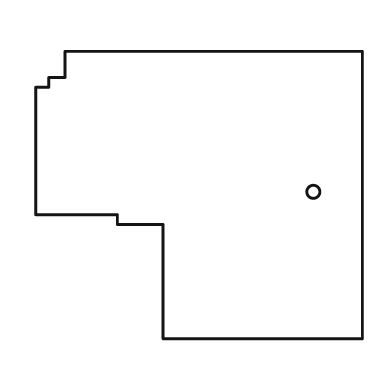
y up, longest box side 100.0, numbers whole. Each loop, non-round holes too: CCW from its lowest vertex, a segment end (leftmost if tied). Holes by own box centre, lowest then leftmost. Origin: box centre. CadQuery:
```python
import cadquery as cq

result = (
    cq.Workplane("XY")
    .moveTo(-11.0, -44.0)
    .lineTo(50.0, -44.0)
    .lineTo(50.0, 44.0)
    .lineTo(-41.0, 44.0)
    .lineTo(-41.0, 36.0)
    .lineTo(-46.0, 36.0)
    .lineTo(-46.0, 33.0)
    .lineTo(-50.0, 33.0)
    .lineTo(-50.0, -6.0)
    .lineTo(-25.0, -6.0)
    .lineTo(-25.0, -9.0)
    .lineTo(-11.0, -9.0)
    .close()
    .moveTo(35.0, 1.0)
    .circle(2.0)
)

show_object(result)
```